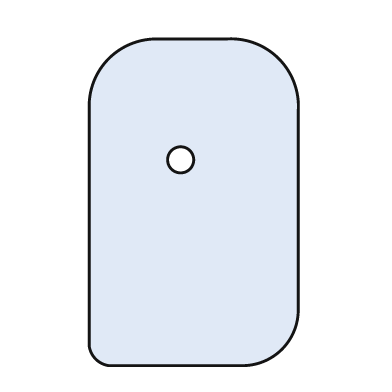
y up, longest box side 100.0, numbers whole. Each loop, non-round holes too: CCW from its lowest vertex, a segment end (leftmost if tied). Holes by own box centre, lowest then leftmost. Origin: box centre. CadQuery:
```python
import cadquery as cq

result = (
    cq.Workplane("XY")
    .moveTo(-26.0, -50.0)
    .lineTo(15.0, -50.0)
    .threePointArc((27.0, -45.0), (32.0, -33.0))
    .lineTo(32.0, 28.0)
    .threePointArc((26.0, 44.0), (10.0, 50.0))
    .lineTo(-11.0, 50.0)
    .threePointArc((-26.0, 44.0), (-32.0, 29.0))
    .lineTo(-32.0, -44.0)
    .threePointArc((-30.0, -48.0), (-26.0, -50.0))
    .close()
    .moveTo(-4.0, 13.0)
    .circle(4.0)
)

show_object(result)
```